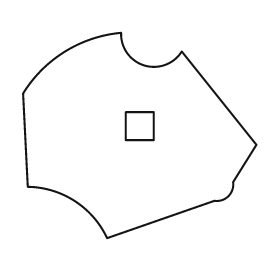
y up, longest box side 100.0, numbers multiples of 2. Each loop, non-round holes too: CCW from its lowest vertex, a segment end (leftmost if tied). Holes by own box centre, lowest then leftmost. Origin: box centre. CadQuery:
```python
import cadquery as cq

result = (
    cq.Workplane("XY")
    .moveTo(-14.0, -44.0)
    .lineTo(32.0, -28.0)
    .threePointArc((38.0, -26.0), (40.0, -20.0))
    .lineTo(50.0, -4.0)
    .lineTo(18.0, 36.0)
    .threePointArc((2.0, 30.0), (-8.0, 44.0))
    .threePointArc((-32.0, 36.0), (-50.0, 18.0))
    .lineTo(-48.0, -22.0)
    .threePointArc((-28.0, -28.0), (-14.0, -44.0))
    .close()
    .moveTo(-6.0, -2.0)
    .lineTo(6.0, -2.0)
    .lineTo(6.0, 10.0)
    .lineTo(-6.0, 10.0)
    .close()
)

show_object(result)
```